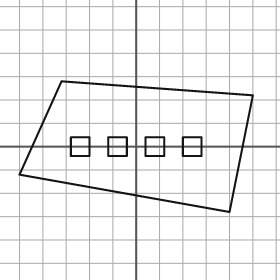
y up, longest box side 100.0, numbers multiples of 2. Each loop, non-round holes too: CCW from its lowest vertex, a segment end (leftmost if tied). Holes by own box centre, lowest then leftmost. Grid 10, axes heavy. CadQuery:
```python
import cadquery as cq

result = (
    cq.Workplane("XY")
    .moveTo(40.0, -28.0)
    .lineTo(50.0, 22.0)
    .lineTo(-32.0, 28.0)
    .lineTo(-50.0, -12.0)
    .close()
    .moveTo(-28.0, -4.0)
    .lineTo(-20.0, -4.0)
    .lineTo(-20.0, 4.0)
    .lineTo(-28.0, 4.0)
    .close()
    .moveTo(-12.0, -4.0)
    .lineTo(-4.0, -4.0)
    .lineTo(-4.0, 4.0)
    .lineTo(-12.0, 4.0)
    .close()
    .moveTo(4.0, -4.0)
    .lineTo(12.0, -4.0)
    .lineTo(12.0, 4.0)
    .lineTo(4.0, 4.0)
    .close()
    .moveTo(20.0, -4.0)
    .lineTo(28.0, -4.0)
    .lineTo(28.0, 4.0)
    .lineTo(20.0, 4.0)
    .close()
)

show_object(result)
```